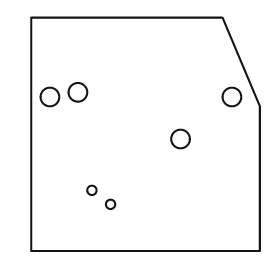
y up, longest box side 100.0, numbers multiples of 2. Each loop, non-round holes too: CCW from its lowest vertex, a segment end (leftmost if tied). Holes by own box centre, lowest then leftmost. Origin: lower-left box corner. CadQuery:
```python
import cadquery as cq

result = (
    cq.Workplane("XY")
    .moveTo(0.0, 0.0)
    .lineTo(98.0, 0.0)
    .lineTo(98.0, 62.0)
    .lineTo(82.0, 100.0)
    .lineTo(0.0, 100.0)
    .close()
    .moveTo(34.0, 20.0)
    .circle(2.0)
    .moveTo(26.0, 26.0)
    .circle(2.0)
    .moveTo(64.0, 48.0)
    .circle(4.0)
    .moveTo(8.0, 66.0)
    .circle(4.0)
    .moveTo(86.0, 66.0)
    .circle(4.0)
    .moveTo(20.0, 68.0)
    .circle(4.0)
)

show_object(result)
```